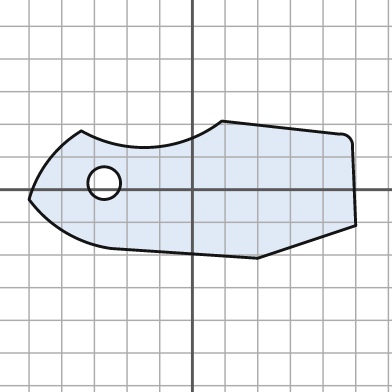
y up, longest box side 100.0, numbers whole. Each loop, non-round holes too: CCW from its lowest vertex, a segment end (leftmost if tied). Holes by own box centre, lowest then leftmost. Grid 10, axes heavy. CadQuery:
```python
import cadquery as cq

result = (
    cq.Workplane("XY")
    .moveTo(20.0, -21.0)
    .lineTo(50.0, -11.0)
    .lineTo(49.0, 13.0)
    .threePointArc((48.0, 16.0), (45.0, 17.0))
    .lineTo(9.0, 21.0)
    .threePointArc((-12.0, 13.0), (-34.0, 18.0))
    .threePointArc((-44.0, 9.0), (-50.0, -3.0))
    .threePointArc((-39.0, -13.0), (-25.0, -18.0))
    .close()
    .moveTo(-27.0, 2.0)
    .circle(5.0)
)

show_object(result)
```